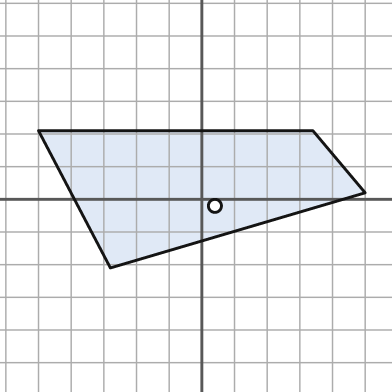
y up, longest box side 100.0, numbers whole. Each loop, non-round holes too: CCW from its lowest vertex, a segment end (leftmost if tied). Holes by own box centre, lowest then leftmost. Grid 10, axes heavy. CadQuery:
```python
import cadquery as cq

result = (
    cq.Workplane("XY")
    .moveTo(-28.0, -21.0)
    .lineTo(50.0, 2.0)
    .lineTo(34.0, 21.0)
    .lineTo(-50.0, 21.0)
    .close()
    .moveTo(4.0, -2.0)
    .circle(2.0)
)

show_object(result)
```